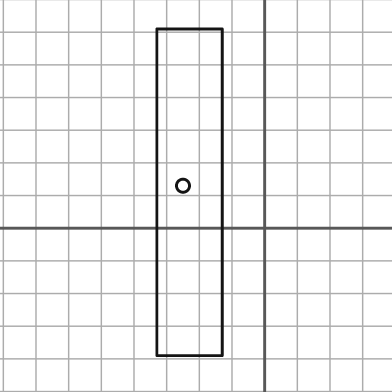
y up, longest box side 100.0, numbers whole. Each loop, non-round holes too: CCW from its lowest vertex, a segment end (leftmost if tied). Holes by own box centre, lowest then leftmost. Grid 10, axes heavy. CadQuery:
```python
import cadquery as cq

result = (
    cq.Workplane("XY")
    .moveTo(-33.0, -39.0)
    .lineTo(-13.0, -39.0)
    .lineTo(-13.0, 61.0)
    .lineTo(-33.0, 61.0)
    .close()
    .moveTo(-25.0, 13.0)
    .circle(2.0)
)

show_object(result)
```